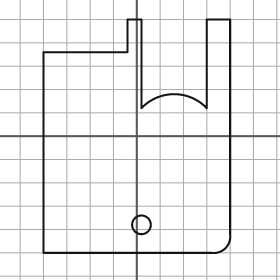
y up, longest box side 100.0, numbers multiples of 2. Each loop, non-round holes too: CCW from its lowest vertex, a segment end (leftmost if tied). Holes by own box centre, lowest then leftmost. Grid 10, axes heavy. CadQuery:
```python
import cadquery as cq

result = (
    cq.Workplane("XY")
    .moveTo(-40.0, -50.0)
    .lineTo(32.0, -50.0)
    .threePointArc((38.0, -48.0), (40.0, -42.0))
    .lineTo(40.0, 50.0)
    .lineTo(30.0, 50.0)
    .lineTo(30.0, 12.0)
    .threePointArc((16.0, 18.0), (2.0, 12.0))
    .lineTo(2.0, 50.0)
    .lineTo(-4.0, 50.0)
    .lineTo(-4.0, 36.0)
    .lineTo(-40.0, 36.0)
    .close()
    .moveTo(2.0, -38.0)
    .circle(4.0)
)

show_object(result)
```